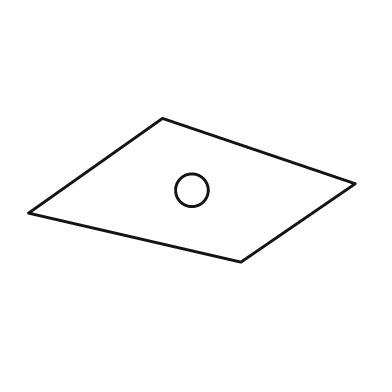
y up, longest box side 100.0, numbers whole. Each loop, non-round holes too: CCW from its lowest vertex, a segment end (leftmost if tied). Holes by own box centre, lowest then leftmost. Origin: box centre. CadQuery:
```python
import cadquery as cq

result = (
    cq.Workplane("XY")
    .moveTo(15.0, -22.0)
    .lineTo(50.0, 2.0)
    .lineTo(-9.0, 22.0)
    .lineTo(-50.0, -7.0)
    .close()
    .moveTo(0.0, 0.0)
    .circle(5.0)
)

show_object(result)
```